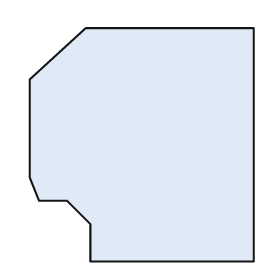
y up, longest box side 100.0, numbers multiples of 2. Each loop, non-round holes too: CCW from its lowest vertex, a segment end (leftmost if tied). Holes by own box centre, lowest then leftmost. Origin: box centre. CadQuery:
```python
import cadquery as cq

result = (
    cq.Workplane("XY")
    .moveTo(-22.0, -50.0)
    .lineTo(48.0, -50.0)
    .lineTo(48.0, 50.0)
    .lineTo(-24.0, 50.0)
    .lineTo(-48.0, 28.0)
    .lineTo(-48.0, -14.0)
    .lineTo(-44.0, -24.0)
    .lineTo(-32.0, -24.0)
    .lineTo(-22.0, -34.0)
    .close()
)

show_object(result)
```